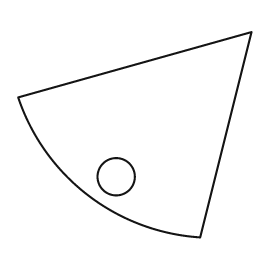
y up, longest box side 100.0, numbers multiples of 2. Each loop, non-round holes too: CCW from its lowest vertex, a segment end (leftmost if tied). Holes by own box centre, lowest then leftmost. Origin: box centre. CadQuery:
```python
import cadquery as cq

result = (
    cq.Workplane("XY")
    .moveTo(28.0, -44.0)
    .lineTo(50.0, 44.0)
    .lineTo(-50.0, 16.0)
    .threePointArc((-20.0, -26.0), (28.0, -44.0))
    .close()
    .moveTo(-8.0, -18.0)
    .circle(8.0)
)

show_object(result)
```